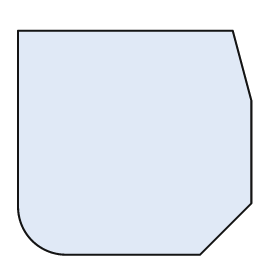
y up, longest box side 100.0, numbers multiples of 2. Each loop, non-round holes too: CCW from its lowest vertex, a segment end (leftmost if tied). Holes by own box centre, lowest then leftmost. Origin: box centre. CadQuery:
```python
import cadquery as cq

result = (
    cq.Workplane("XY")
    .moveTo(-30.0, -48.0)
    .lineTo(28.0, -48.0)
    .lineTo(50.0, -26.0)
    .lineTo(50.0, 18.0)
    .lineTo(42.0, 48.0)
    .lineTo(-50.0, 48.0)
    .lineTo(-50.0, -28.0)
    .threePointArc((-44.0, -42.0), (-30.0, -48.0))
    .close()
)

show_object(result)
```